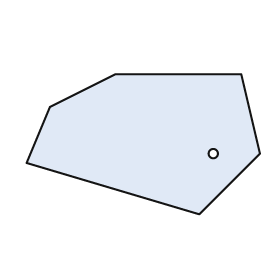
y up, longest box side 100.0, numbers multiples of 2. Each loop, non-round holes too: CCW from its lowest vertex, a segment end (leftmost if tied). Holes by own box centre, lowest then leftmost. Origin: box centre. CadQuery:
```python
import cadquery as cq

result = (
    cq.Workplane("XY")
    .moveTo(24.0, -30.0)
    .lineTo(50.0, -4.0)
    .lineTo(42.0, 30.0)
    .lineTo(-12.0, 30.0)
    .lineTo(-40.0, 16.0)
    .lineTo(-50.0, -8.0)
    .close()
    .moveTo(30.0, -4.0)
    .circle(2.0)
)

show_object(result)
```